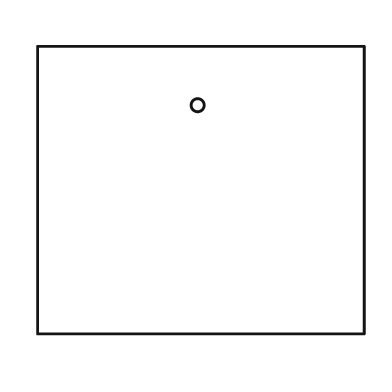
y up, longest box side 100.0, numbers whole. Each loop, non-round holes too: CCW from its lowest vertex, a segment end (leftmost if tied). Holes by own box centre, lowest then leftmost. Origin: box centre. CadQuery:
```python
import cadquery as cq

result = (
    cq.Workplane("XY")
    .moveTo(-50.0, -44.0)
    .lineTo(50.0, -44.0)
    .lineTo(50.0, 44.0)
    .lineTo(-50.0, 44.0)
    .close()
    .moveTo(-1.0, 26.0)
    .circle(2.0)
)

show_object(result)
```